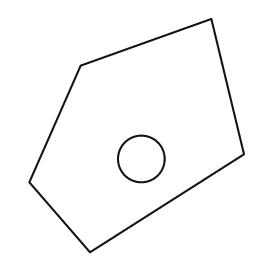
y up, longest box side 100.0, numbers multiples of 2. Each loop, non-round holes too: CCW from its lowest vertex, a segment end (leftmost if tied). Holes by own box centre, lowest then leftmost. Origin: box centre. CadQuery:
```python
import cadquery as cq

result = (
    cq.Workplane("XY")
    .moveTo(-20.0, -50.0)
    .lineTo(46.0, -8.0)
    .lineTo(32.0, 50.0)
    .lineTo(-24.0, 30.0)
    .lineTo(-46.0, -20.0)
    .close()
    .moveTo(2.0, -10.0)
    .circle(10.0)
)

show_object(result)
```